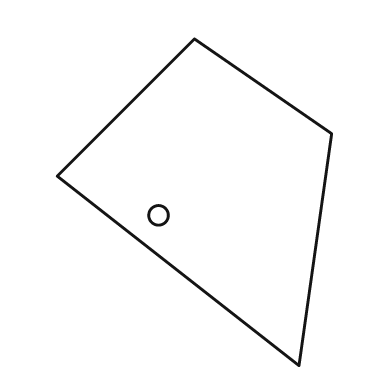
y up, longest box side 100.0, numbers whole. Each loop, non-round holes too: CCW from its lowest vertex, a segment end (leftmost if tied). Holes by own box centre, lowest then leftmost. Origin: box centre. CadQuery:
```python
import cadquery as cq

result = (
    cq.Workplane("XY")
    .moveTo(32.0, -50.0)
    .lineTo(42.0, 21.0)
    .lineTo(0.0, 50.0)
    .lineTo(-42.0, 8.0)
    .close()
    .moveTo(-11.0, -4.0)
    .circle(3.0)
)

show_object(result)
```